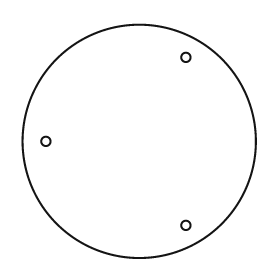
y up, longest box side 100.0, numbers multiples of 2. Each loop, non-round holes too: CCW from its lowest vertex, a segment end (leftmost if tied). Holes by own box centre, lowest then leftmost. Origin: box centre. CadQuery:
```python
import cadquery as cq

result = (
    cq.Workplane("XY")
    .moveTo(0.0, 0.0)
    .circle(50.0)
    .moveTo(20.0, -36.0)
    .circle(2.0)
    .moveTo(-40.0, 0.0)
    .circle(2.0)
    .moveTo(20.0, 36.0)
    .circle(2.0)
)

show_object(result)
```